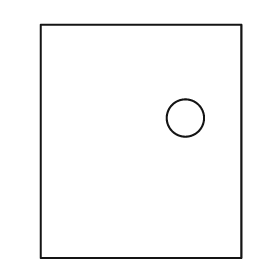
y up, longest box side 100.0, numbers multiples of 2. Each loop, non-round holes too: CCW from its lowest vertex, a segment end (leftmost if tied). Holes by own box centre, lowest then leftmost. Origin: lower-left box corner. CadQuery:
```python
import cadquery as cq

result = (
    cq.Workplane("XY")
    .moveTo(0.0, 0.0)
    .lineTo(86.0, 0.0)
    .lineTo(86.0, 100.0)
    .lineTo(0.0, 100.0)
    .close()
    .moveTo(62.0, 60.0)
    .circle(8.0)
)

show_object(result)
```